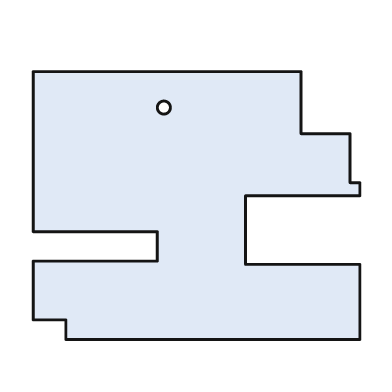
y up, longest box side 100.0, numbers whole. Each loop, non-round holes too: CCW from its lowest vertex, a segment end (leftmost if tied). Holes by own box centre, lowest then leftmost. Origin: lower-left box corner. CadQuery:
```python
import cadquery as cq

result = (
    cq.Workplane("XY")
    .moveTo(10.0, 0.0)
    .lineTo(100.0, 0.0)
    .lineTo(100.0, 23.0)
    .lineTo(65.0, 23.0)
    .lineTo(65.0, 44.0)
    .lineTo(100.0, 44.0)
    .lineTo(100.0, 48.0)
    .lineTo(97.0, 48.0)
    .lineTo(97.0, 63.0)
    .lineTo(82.0, 63.0)
    .lineTo(82.0, 82.0)
    .lineTo(0.0, 82.0)
    .lineTo(0.0, 33.0)
    .lineTo(38.0, 33.0)
    .lineTo(38.0, 24.0)
    .lineTo(0.0, 24.0)
    .lineTo(0.0, 6.0)
    .lineTo(10.0, 6.0)
    .close()
    .moveTo(40.0, 71.0)
    .circle(2.0)
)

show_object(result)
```